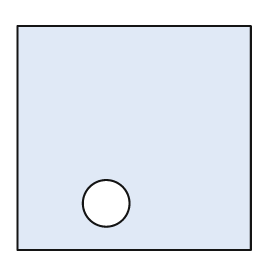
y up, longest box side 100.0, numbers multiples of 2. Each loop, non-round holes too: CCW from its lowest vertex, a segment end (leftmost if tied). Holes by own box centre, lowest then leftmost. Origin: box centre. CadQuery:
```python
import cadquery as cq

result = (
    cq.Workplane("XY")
    .moveTo(-50.0, -48.0)
    .lineTo(50.0, -48.0)
    .lineTo(50.0, 48.0)
    .lineTo(-50.0, 48.0)
    .close()
    .moveTo(-12.0, -28.0)
    .circle(10.0)
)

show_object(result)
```